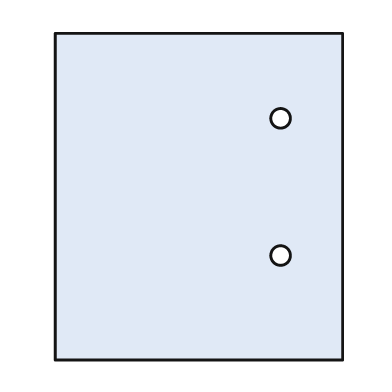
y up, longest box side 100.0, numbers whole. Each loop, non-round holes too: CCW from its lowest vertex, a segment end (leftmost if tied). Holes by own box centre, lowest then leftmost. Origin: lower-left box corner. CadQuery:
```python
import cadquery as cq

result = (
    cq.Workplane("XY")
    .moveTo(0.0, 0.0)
    .lineTo(88.0, 0.0)
    .lineTo(88.0, 100.0)
    .lineTo(0.0, 100.0)
    .close()
    .moveTo(69.0, 32.0)
    .circle(3.0)
    .moveTo(69.0, 74.0)
    .circle(3.0)
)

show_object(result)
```